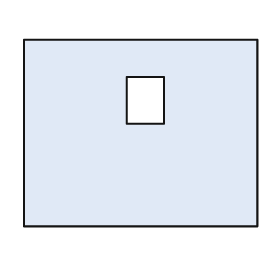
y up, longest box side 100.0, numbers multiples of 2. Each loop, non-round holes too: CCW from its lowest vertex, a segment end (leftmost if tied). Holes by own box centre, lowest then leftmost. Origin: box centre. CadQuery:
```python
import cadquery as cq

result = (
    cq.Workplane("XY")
    .moveTo(-50.0, -40.0)
    .lineTo(50.0, -40.0)
    .lineTo(50.0, 40.0)
    .lineTo(-50.0, 40.0)
    .close()
    .moveTo(-6.0, 4.0)
    .lineTo(10.0, 4.0)
    .lineTo(10.0, 24.0)
    .lineTo(-6.0, 24.0)
    .close()
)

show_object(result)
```